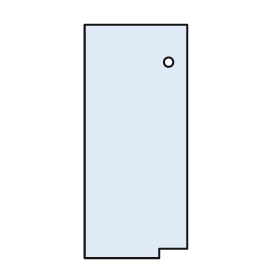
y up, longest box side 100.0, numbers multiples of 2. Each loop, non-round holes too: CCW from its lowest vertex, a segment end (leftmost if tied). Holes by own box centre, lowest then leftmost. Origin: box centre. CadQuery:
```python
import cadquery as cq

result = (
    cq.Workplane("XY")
    .moveTo(-22.0, -50.0)
    .lineTo(10.0, -50.0)
    .lineTo(10.0, -46.0)
    .lineTo(22.0, -46.0)
    .lineTo(22.0, 50.0)
    .lineTo(-22.0, 50.0)
    .close()
    .moveTo(14.0, 34.0)
    .circle(2.0)
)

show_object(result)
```